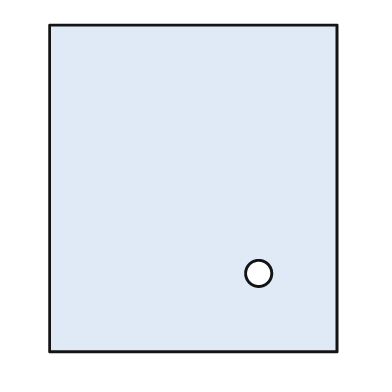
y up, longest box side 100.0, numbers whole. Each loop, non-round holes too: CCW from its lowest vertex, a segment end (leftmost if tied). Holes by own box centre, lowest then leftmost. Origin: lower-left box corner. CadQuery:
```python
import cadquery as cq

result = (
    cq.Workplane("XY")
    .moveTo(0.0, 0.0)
    .lineTo(88.0, 0.0)
    .lineTo(88.0, 100.0)
    .lineTo(0.0, 100.0)
    .close()
    .moveTo(64.0, 24.0)
    .circle(4.0)
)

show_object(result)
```